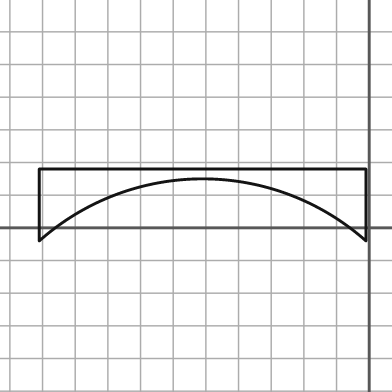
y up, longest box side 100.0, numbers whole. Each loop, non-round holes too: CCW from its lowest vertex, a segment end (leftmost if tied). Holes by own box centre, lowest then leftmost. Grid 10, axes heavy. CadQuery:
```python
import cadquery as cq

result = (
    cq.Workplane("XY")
    .moveTo(-101.0, -4.0)
    .threePointArc((-51.0, 15.0), (-1.0, -4.0))
    .lineTo(-1.0, 18.0)
    .lineTo(-101.0, 18.0)
    .close()
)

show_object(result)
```